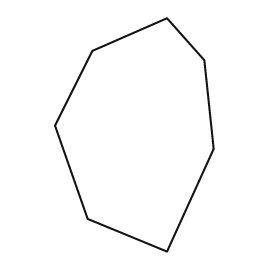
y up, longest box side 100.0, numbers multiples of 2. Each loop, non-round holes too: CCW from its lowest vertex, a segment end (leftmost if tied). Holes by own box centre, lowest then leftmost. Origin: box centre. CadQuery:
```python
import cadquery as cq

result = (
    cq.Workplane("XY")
    .moveTo(14.0, -50.0)
    .lineTo(34.0, -6.0)
    .lineTo(30.0, 32.0)
    .lineTo(14.0, 50.0)
    .lineTo(-18.0, 36.0)
    .lineTo(-34.0, 4.0)
    .lineTo(-20.0, -36.0)
    .close()
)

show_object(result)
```